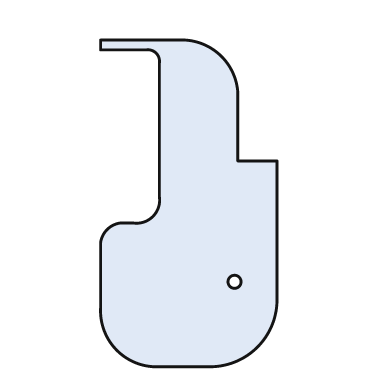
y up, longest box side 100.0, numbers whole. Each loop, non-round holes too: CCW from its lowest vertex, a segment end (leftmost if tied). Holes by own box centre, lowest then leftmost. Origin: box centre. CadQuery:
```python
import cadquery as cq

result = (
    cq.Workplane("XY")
    .moveTo(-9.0, -50.0)
    .lineTo(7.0, -50.0)
    .threePointArc((21.0, -44.0), (27.0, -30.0))
    .lineTo(27.0, 13.0)
    .lineTo(15.0, 13.0)
    .lineTo(15.0, 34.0)
    .threePointArc((10.0, 45.0), (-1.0, 50.0))
    .lineTo(-27.0, 50.0)
    .lineTo(-27.0, 47.0)
    .lineTo(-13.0, 47.0)
    .threePointArc((-10.0, 46.0), (-9.0, 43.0))
    .lineTo(-9.0, 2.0)
    .threePointArc((-11.0, -4.0), (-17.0, -6.0))
    .lineTo(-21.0, -6.0)
    .threePointArc((-25.0, -8.0), (-27.0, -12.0))
    .lineTo(-27.0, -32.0)
    .threePointArc((-22.0, -45.0), (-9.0, -50.0))
    .close()
    .moveTo(14.0, -24.0)
    .circle(2.0)
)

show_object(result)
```